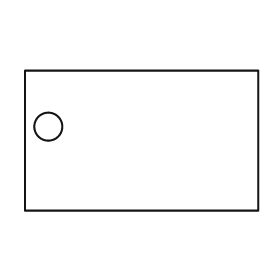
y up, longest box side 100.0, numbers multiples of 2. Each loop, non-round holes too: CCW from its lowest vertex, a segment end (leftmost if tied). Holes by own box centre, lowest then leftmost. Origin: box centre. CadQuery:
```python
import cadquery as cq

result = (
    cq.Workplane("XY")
    .moveTo(-50.0, -30.0)
    .lineTo(50.0, -30.0)
    .lineTo(50.0, 30.0)
    .lineTo(-50.0, 30.0)
    .close()
    .moveTo(-40.0, 6.0)
    .circle(6.0)
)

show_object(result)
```